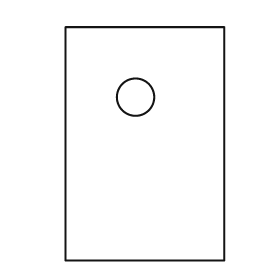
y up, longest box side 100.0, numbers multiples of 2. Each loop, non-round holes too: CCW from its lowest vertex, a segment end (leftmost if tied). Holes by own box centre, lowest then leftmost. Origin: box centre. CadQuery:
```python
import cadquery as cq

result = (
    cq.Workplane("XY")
    .moveTo(-34.0, -50.0)
    .lineTo(34.0, -50.0)
    .lineTo(34.0, 50.0)
    .lineTo(-34.0, 50.0)
    .close()
    .moveTo(-4.0, 20.0)
    .circle(8.0)
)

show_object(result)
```